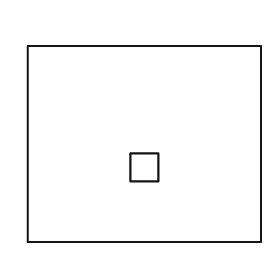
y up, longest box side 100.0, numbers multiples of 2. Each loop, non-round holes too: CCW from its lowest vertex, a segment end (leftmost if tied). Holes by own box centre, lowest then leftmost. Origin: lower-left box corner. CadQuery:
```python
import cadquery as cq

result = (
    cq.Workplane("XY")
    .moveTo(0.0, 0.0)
    .lineTo(100.0, 0.0)
    .lineTo(100.0, 84.0)
    .lineTo(0.0, 84.0)
    .close()
    .moveTo(44.0, 26.0)
    .lineTo(56.0, 26.0)
    .lineTo(56.0, 38.0)
    .lineTo(44.0, 38.0)
    .close()
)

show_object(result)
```